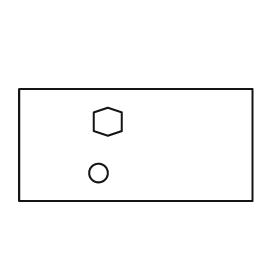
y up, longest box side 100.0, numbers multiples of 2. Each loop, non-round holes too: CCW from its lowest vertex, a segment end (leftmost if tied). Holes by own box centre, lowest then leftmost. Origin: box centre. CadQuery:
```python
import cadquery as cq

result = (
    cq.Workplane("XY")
    .moveTo(-50.0, -24.0)
    .lineTo(50.0, -24.0)
    .lineTo(50.0, 24.0)
    .lineTo(-50.0, 24.0)
    .close()
    .moveTo(-16.0, -12.0)
    .circle(4.0)
    .moveTo(-12.0, 4.0)
    .lineTo(-6.0, 6.0)
    .lineTo(-6.0, 14.0)
    .lineTo(-12.0, 16.0)
    .lineTo(-18.0, 14.0)
    .lineTo(-18.0, 6.0)
    .close()
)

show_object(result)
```